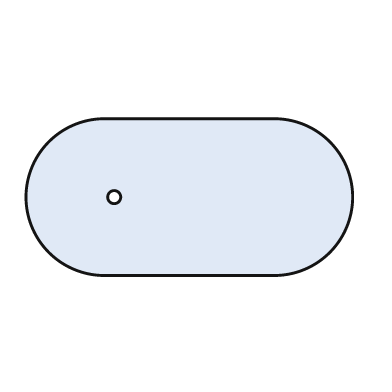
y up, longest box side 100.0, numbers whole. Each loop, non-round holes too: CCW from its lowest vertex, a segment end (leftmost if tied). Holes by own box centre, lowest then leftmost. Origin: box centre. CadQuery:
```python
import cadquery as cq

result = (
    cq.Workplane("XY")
    .moveTo(-26.0, -24.0)
    .lineTo(26.0, -24.0)
    .threePointArc((50.0, 0.0), (26.0, 24.0))
    .lineTo(-26.0, 24.0)
    .threePointArc((-50.0, 0.0), (-26.0, -24.0))
    .close()
    .moveTo(-23.0, 0.0)
    .circle(2.0)
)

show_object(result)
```